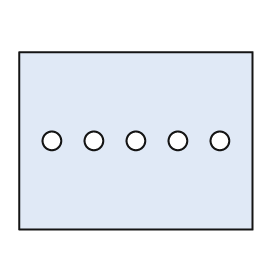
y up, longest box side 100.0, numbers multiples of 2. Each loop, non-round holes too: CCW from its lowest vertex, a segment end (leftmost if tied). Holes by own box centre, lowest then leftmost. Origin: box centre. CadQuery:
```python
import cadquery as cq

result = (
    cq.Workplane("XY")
    .moveTo(-50.0, -38.0)
    .lineTo(50.0, -38.0)
    .lineTo(50.0, 38.0)
    .lineTo(-50.0, 38.0)
    .close()
    .moveTo(-36.0, 0.0)
    .circle(4.0)
    .moveTo(-18.0, 0.0)
    .circle(4.0)
    .moveTo(0.0, 0.0)
    .circle(4.0)
    .moveTo(18.0, 0.0)
    .circle(4.0)
    .moveTo(36.0, 0.0)
    .circle(4.0)
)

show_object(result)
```